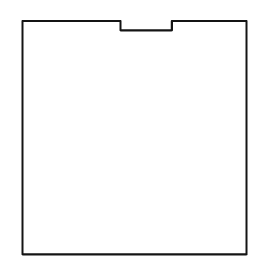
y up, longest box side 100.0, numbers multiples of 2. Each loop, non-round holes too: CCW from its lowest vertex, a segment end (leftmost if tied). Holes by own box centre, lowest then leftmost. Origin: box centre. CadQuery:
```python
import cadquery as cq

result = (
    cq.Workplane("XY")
    .moveTo(-48.0, -50.0)
    .lineTo(48.0, -50.0)
    .lineTo(48.0, 50.0)
    .lineTo(16.0, 50.0)
    .lineTo(16.0, 46.0)
    .lineTo(-6.0, 46.0)
    .lineTo(-6.0, 50.0)
    .lineTo(-48.0, 50.0)
    .close()
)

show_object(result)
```